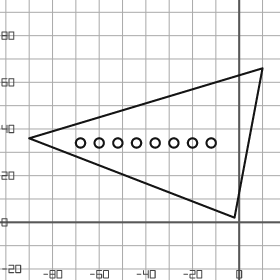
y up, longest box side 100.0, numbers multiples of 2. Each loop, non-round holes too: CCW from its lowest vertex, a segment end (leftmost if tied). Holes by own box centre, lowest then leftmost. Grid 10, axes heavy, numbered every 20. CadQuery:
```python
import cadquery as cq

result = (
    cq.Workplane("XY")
    .moveTo(-2.0, 2.0)
    .lineTo(10.0, 66.0)
    .lineTo(-90.0, 36.0)
    .close()
    .moveTo(-68.0, 34.0)
    .circle(2.0)
    .moveTo(-60.0, 34.0)
    .circle(2.0)
    .moveTo(-52.0, 34.0)
    .circle(2.0)
    .moveTo(-44.0, 34.0)
    .circle(2.0)
    .moveTo(-36.0, 34.0)
    .circle(2.0)
    .moveTo(-28.0, 34.0)
    .circle(2.0)
    .moveTo(-20.0, 34.0)
    .circle(2.0)
    .moveTo(-12.0, 34.0)
    .circle(2.0)
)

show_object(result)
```